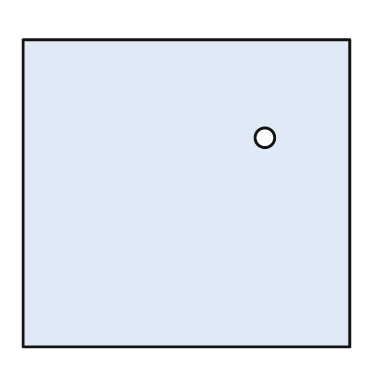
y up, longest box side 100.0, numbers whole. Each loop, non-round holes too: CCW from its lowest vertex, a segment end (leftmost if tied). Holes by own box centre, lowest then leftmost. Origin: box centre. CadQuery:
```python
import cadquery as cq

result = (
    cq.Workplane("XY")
    .moveTo(-50.0, -47.0)
    .lineTo(50.0, -47.0)
    .lineTo(50.0, 47.0)
    .lineTo(-50.0, 47.0)
    .close()
    .moveTo(24.0, 17.0)
    .circle(3.0)
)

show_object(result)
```